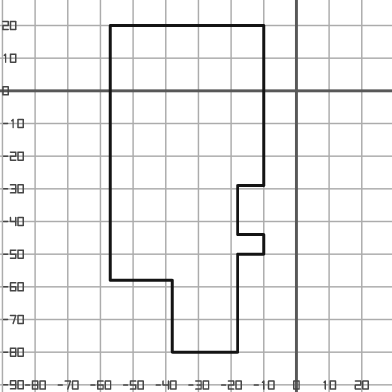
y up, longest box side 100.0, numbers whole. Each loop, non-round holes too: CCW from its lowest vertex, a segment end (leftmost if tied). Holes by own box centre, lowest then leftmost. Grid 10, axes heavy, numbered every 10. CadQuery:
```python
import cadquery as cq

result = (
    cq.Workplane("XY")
    .moveTo(-38.0, -80.0)
    .lineTo(-18.0, -80.0)
    .lineTo(-18.0, -50.0)
    .lineTo(-10.0, -50.0)
    .lineTo(-10.0, -44.0)
    .lineTo(-18.0, -44.0)
    .lineTo(-18.0, -29.0)
    .lineTo(-10.0, -29.0)
    .lineTo(-10.0, 20.0)
    .lineTo(-57.0, 20.0)
    .lineTo(-57.0, -58.0)
    .lineTo(-38.0, -58.0)
    .close()
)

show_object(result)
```